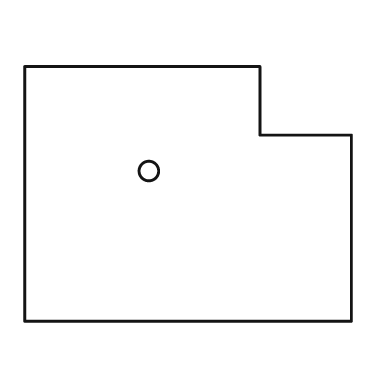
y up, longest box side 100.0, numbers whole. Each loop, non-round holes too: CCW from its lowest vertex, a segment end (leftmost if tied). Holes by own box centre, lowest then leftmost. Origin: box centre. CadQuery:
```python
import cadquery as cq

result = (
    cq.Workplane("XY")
    .moveTo(-50.0, -39.0)
    .lineTo(50.0, -39.0)
    .lineTo(50.0, 18.0)
    .lineTo(22.0, 18.0)
    .lineTo(22.0, 39.0)
    .lineTo(-50.0, 39.0)
    .close()
    .moveTo(-12.0, 7.0)
    .circle(3.0)
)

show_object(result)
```